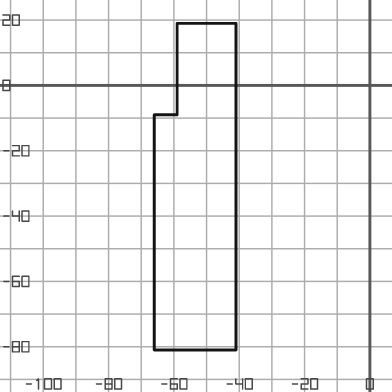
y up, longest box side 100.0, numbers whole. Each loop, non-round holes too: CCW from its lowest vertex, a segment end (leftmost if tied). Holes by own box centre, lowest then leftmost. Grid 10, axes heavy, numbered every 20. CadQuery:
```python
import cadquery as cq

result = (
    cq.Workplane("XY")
    .moveTo(-66.0, -81.0)
    .lineTo(-41.0, -81.0)
    .lineTo(-41.0, 19.0)
    .lineTo(-59.0, 19.0)
    .lineTo(-59.0, -9.0)
    .lineTo(-66.0, -9.0)
    .close()
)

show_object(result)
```